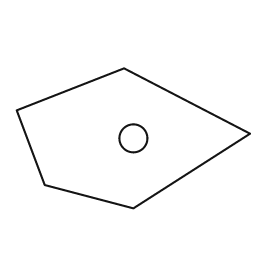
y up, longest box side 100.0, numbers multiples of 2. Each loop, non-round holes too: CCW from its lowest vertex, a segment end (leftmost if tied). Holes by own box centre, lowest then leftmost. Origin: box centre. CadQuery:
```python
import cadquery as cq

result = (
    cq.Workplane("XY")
    .moveTo(0.0, -30.0)
    .lineTo(50.0, 2.0)
    .lineTo(-4.0, 30.0)
    .lineTo(-50.0, 12.0)
    .lineTo(-38.0, -20.0)
    .close()
    .moveTo(0.0, 0.0)
    .circle(6.0)
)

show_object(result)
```